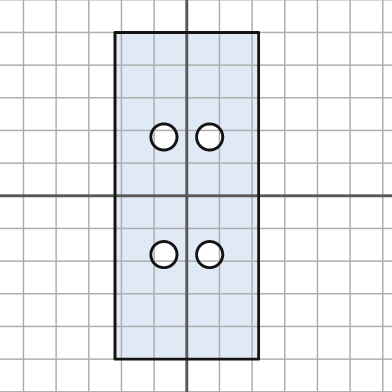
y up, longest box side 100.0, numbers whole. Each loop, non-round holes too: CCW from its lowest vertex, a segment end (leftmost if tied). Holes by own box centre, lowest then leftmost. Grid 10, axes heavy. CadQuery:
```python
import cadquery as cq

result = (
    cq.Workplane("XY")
    .moveTo(-22.0, -50.0)
    .lineTo(22.0, -50.0)
    .lineTo(22.0, 50.0)
    .lineTo(-22.0, 50.0)
    .close()
    .moveTo(-7.0, -18.0)
    .circle(4.0)
    .moveTo(7.0, -18.0)
    .circle(4.0)
    .moveTo(-7.0, 18.0)
    .circle(4.0)
    .moveTo(7.0, 18.0)
    .circle(4.0)
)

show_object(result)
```